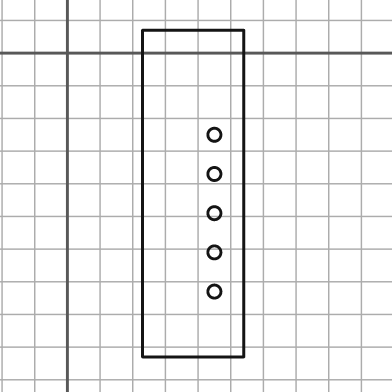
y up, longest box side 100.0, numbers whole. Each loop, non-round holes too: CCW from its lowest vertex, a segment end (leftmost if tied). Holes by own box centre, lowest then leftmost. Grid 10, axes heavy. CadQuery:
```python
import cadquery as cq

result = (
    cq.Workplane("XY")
    .moveTo(23.0, -93.0)
    .lineTo(54.0, -93.0)
    .lineTo(54.0, 7.0)
    .lineTo(23.0, 7.0)
    .close()
    .moveTo(45.0, -73.0)
    .circle(2.0)
    .moveTo(45.0, -61.0)
    .circle(2.0)
    .moveTo(45.0, -49.0)
    .circle(2.0)
    .moveTo(45.0, -37.0)
    .circle(2.0)
    .moveTo(45.0, -25.0)
    .circle(2.0)
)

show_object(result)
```